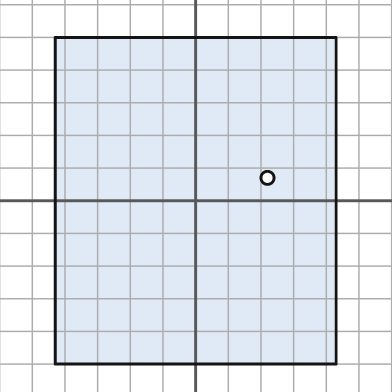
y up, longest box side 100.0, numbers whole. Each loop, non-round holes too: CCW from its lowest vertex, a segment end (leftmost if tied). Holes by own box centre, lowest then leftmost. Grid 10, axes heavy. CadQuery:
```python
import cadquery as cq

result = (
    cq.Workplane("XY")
    .moveTo(-43.0, -50.0)
    .lineTo(43.0, -50.0)
    .lineTo(43.0, 50.0)
    .lineTo(-43.0, 50.0)
    .close()
    .moveTo(22.0, 7.0)
    .circle(2.0)
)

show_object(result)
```